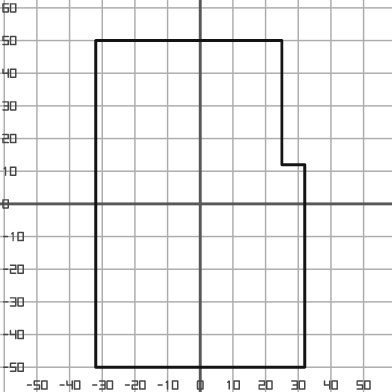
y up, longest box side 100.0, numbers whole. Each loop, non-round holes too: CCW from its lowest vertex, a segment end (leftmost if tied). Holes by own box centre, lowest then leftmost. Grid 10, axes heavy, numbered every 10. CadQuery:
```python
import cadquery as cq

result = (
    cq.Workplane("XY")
    .moveTo(-32.0, -50.0)
    .lineTo(32.0, -50.0)
    .lineTo(32.0, 12.0)
    .lineTo(25.0, 12.0)
    .lineTo(25.0, 50.0)
    .lineTo(-32.0, 50.0)
    .close()
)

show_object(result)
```